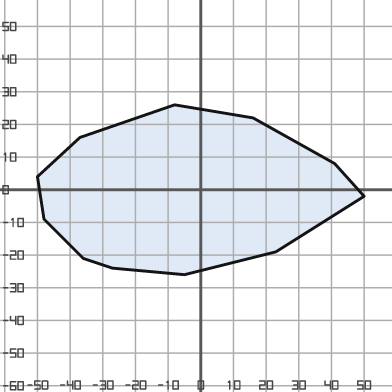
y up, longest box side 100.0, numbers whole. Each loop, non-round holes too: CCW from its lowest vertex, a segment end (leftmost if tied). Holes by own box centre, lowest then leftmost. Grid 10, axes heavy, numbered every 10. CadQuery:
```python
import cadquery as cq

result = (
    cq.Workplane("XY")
    .moveTo(-5.0, -26.0)
    .lineTo(23.0, -19.0)
    .lineTo(50.0, -2.0)
    .lineTo(41.0, 8.0)
    .lineTo(16.0, 22.0)
    .lineTo(-8.0, 26.0)
    .lineTo(-37.0, 16.0)
    .lineTo(-50.0, 4.0)
    .lineTo(-48.0, -9.0)
    .lineTo(-36.0, -21.0)
    .lineTo(-27.0, -24.0)
    .close()
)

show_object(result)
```